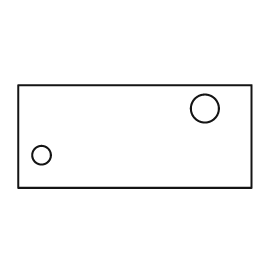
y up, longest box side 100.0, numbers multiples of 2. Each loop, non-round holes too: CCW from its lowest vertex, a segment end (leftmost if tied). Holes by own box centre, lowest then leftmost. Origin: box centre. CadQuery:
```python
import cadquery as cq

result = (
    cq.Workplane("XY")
    .moveTo(-50.0, -22.0)
    .lineTo(50.0, -22.0)
    .lineTo(50.0, 22.0)
    .lineTo(-50.0, 22.0)
    .close()
    .moveTo(-40.0, -8.0)
    .circle(4.0)
    .moveTo(30.0, 12.0)
    .circle(6.0)
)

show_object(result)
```